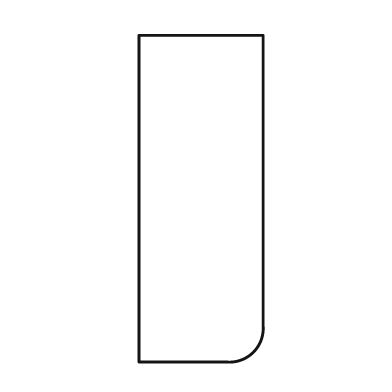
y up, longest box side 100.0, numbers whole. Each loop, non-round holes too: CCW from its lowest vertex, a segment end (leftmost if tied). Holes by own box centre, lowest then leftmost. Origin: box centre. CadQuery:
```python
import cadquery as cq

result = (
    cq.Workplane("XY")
    .moveTo(-19.0, -50.0)
    .lineTo(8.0, -50.0)
    .threePointArc((16.0, -47.0), (19.0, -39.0))
    .lineTo(19.0, 50.0)
    .lineTo(-19.0, 50.0)
    .close()
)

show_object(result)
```